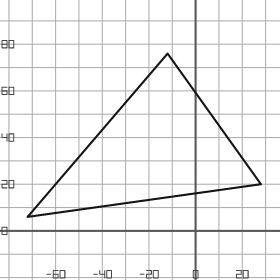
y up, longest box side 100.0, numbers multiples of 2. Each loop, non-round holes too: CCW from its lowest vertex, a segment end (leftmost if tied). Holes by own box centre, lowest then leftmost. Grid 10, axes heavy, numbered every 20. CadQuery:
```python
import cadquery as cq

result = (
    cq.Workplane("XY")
    .moveTo(-72.0, 6.0)
    .lineTo(28.0, 20.0)
    .lineTo(-12.0, 76.0)
    .close()
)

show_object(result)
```